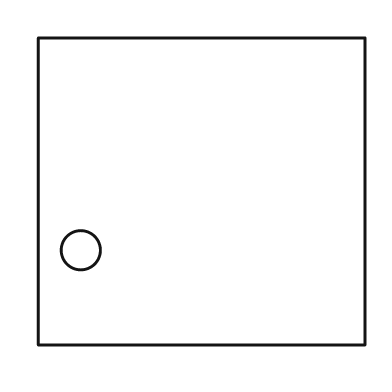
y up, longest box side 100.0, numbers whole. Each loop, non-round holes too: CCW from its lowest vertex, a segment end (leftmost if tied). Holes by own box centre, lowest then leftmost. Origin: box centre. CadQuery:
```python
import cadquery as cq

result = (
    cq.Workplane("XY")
    .moveTo(-50.0, -47.0)
    .lineTo(50.0, -47.0)
    .lineTo(50.0, 47.0)
    .lineTo(-50.0, 47.0)
    .close()
    .moveTo(-37.0, -18.0)
    .circle(6.0)
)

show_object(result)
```